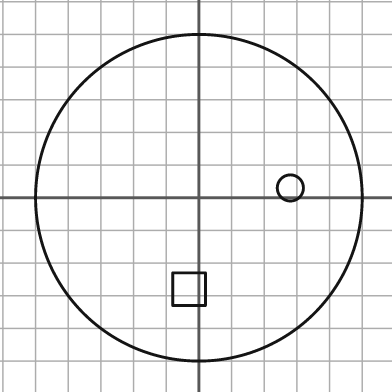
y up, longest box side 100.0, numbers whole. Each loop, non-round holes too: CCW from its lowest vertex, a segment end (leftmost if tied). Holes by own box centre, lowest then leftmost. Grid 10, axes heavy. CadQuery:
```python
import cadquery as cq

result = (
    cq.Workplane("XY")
    .moveTo(0.0, 0.0)
    .circle(50.0)
    .moveTo(-8.0, -33.0)
    .lineTo(2.0, -33.0)
    .lineTo(2.0, -23.0)
    .lineTo(-8.0, -23.0)
    .close()
    .moveTo(28.0, 3.0)
    .circle(4.0)
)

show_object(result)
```